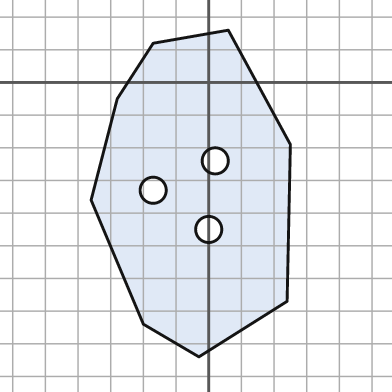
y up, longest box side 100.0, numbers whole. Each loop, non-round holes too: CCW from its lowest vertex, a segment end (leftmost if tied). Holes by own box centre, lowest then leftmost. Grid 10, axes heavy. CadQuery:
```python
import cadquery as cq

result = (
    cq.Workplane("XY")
    .moveTo(-3.0, -84.0)
    .lineTo(24.0, -67.0)
    .lineTo(25.0, -19.0)
    .lineTo(6.0, 16.0)
    .lineTo(-17.0, 12.0)
    .lineTo(-28.0, -5.0)
    .lineTo(-36.0, -36.0)
    .lineTo(-20.0, -74.0)
    .close()
    .moveTo(0.0, -45.0)
    .circle(4.0)
    .moveTo(-17.0, -33.0)
    .circle(4.0)
    .moveTo(2.0, -24.0)
    .circle(4.0)
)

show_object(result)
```